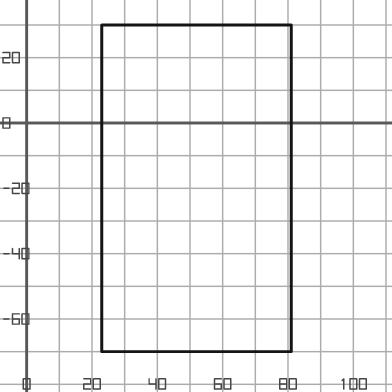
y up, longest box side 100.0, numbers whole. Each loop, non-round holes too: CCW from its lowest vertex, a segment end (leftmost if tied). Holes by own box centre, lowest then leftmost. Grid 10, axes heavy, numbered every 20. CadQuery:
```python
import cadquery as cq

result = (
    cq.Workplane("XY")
    .moveTo(23.0, -70.0)
    .lineTo(81.0, -70.0)
    .lineTo(81.0, 30.0)
    .lineTo(23.0, 30.0)
    .close()
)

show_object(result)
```